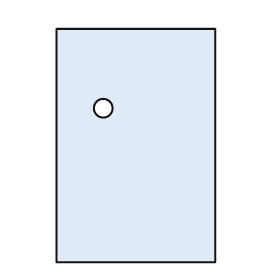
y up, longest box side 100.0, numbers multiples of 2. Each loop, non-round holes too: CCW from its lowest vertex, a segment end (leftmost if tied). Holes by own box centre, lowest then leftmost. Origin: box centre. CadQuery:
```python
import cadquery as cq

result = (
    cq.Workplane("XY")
    .moveTo(-34.0, -50.0)
    .lineTo(34.0, -50.0)
    .lineTo(34.0, 50.0)
    .lineTo(-34.0, 50.0)
    .close()
    .moveTo(-14.0, 16.0)
    .circle(4.0)
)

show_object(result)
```